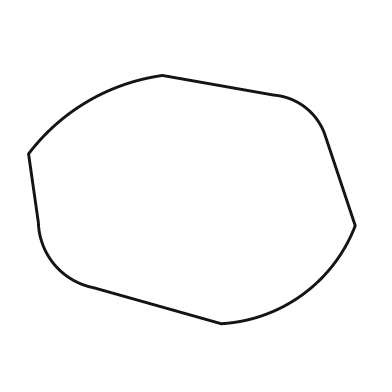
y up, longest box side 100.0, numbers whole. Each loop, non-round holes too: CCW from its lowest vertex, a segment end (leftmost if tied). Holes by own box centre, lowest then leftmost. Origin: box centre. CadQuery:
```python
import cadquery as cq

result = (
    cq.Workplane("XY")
    .moveTo(9.0, -38.0)
    .threePointArc((34.0, -29.0), (50.0, -8.0))
    .lineTo(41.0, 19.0)
    .threePointArc((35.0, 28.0), (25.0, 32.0))
    .lineTo(-9.0, 38.0)
    .threePointArc((-32.0, 30.0), (-50.0, 14.0))
    .lineTo(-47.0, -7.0)
    .threePointArc((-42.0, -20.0), (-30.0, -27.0))
    .close()
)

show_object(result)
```